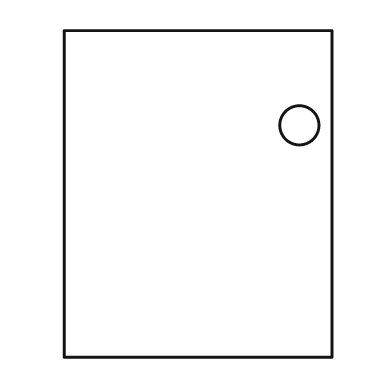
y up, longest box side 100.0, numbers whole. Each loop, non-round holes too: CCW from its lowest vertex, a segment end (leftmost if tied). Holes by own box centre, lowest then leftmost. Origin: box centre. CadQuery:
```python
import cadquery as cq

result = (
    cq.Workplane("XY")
    .moveTo(-41.0, -50.0)
    .lineTo(41.0, -50.0)
    .lineTo(41.0, 50.0)
    .lineTo(-41.0, 50.0)
    .close()
    .moveTo(31.0, 21.0)
    .circle(6.0)
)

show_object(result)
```